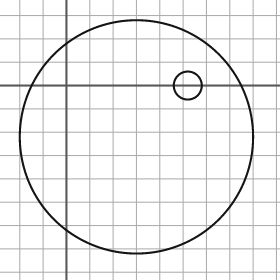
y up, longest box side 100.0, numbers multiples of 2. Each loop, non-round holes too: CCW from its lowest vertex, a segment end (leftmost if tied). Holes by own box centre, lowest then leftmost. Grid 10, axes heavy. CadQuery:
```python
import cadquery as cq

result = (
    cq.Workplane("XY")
    .moveTo(30.0, -22.0)
    .circle(50.0)
    .moveTo(52.0, 0.0)
    .circle(6.0)
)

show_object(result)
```